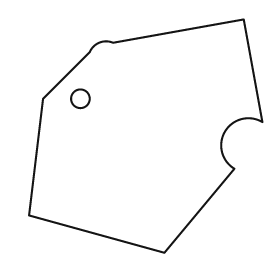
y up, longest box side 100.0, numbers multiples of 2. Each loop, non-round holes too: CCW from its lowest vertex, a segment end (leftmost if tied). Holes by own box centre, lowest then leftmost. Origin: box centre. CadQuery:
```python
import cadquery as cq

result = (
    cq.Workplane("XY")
    .moveTo(8.0, -50.0)
    .lineTo(38.0, -14.0)
    .threePointArc((34.0, 2.0), (50.0, 6.0))
    .lineTo(42.0, 50.0)
    .lineTo(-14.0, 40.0)
    .threePointArc((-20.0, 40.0), (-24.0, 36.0))
    .lineTo(-44.0, 16.0)
    .lineTo(-50.0, -34.0)
    .close()
    .moveTo(-28.0, 16.0)
    .circle(4.0)
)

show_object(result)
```